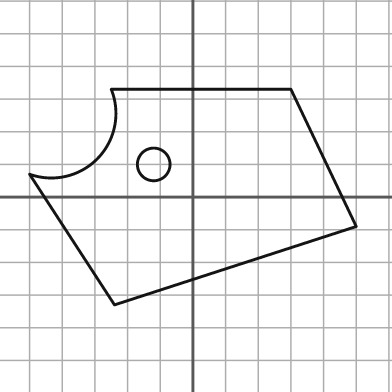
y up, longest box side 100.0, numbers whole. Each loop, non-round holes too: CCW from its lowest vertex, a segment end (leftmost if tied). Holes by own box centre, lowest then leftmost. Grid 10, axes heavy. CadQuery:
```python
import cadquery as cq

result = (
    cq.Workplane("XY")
    .moveTo(-24.0, -33.0)
    .lineTo(50.0, -9.0)
    .lineTo(30.0, 33.0)
    .lineTo(-25.0, 33.0)
    .threePointArc((-29.0, 12.0), (-50.0, 7.0))
    .close()
    .moveTo(-12.0, 10.0)
    .circle(5.0)
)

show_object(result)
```